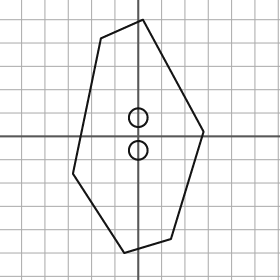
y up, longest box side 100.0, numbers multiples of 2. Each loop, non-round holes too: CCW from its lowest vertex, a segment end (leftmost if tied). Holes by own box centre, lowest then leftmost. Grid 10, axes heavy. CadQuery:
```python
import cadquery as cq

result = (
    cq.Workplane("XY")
    .moveTo(-6.0, -50.0)
    .lineTo(14.0, -44.0)
    .lineTo(28.0, 2.0)
    .lineTo(2.0, 50.0)
    .lineTo(-16.0, 42.0)
    .lineTo(-28.0, -16.0)
    .close()
    .moveTo(0.0, -6.0)
    .circle(4.0)
    .moveTo(0.0, 8.0)
    .circle(4.0)
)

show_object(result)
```